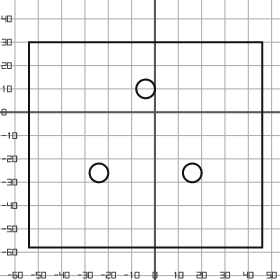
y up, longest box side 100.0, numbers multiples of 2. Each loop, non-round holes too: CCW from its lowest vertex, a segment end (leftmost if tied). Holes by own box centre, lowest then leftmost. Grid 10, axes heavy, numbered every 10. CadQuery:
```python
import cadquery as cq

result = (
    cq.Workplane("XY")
    .moveTo(-54.0, -58.0)
    .lineTo(46.0, -58.0)
    .lineTo(46.0, 30.0)
    .lineTo(-54.0, 30.0)
    .close()
    .moveTo(-24.0, -26.0)
    .circle(4.0)
    .moveTo(16.0, -26.0)
    .circle(4.0)
    .moveTo(-4.0, 10.0)
    .circle(4.0)
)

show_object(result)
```